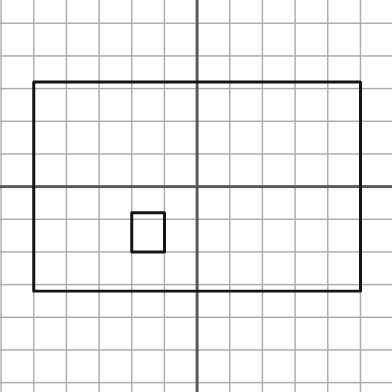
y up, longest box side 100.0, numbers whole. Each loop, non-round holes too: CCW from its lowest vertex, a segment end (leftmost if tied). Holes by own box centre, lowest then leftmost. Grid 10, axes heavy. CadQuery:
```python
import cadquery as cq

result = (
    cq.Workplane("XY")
    .moveTo(-50.0, -32.0)
    .lineTo(50.0, -32.0)
    .lineTo(50.0, 32.0)
    .lineTo(-50.0, 32.0)
    .close()
    .moveTo(-20.0, -20.0)
    .lineTo(-10.0, -20.0)
    .lineTo(-10.0, -8.0)
    .lineTo(-20.0, -8.0)
    .close()
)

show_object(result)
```